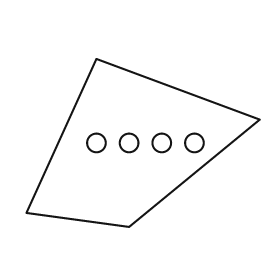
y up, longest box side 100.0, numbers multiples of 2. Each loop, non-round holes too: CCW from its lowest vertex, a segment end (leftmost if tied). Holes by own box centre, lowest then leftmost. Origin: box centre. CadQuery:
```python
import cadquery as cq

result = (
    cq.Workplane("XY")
    .moveTo(-6.0, -36.0)
    .lineTo(50.0, 10.0)
    .lineTo(-20.0, 36.0)
    .lineTo(-50.0, -30.0)
    .close()
    .moveTo(-20.0, 0.0)
    .circle(4.0)
    .moveTo(-6.0, 0.0)
    .circle(4.0)
    .moveTo(8.0, 0.0)
    .circle(4.0)
    .moveTo(22.0, 0.0)
    .circle(4.0)
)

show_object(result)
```